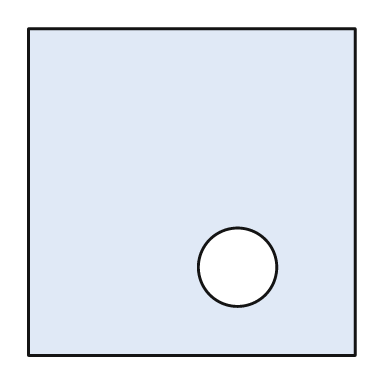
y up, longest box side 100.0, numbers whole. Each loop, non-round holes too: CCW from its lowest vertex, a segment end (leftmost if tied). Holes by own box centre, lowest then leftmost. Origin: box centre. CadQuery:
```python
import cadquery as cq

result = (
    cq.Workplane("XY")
    .moveTo(-50.0, -50.0)
    .lineTo(50.0, -50.0)
    .lineTo(50.0, 50.0)
    .lineTo(-50.0, 50.0)
    .close()
    .moveTo(14.0, -23.0)
    .circle(12.0)
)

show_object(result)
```